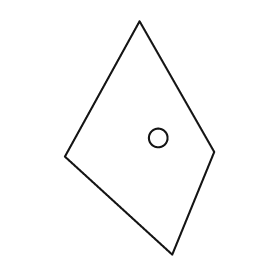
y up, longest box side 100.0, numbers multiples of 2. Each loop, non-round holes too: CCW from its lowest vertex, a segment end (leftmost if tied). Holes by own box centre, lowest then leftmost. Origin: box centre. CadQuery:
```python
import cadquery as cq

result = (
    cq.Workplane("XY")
    .moveTo(14.0, -50.0)
    .lineTo(32.0, -6.0)
    .lineTo(0.0, 50.0)
    .lineTo(-32.0, -8.0)
    .close()
    .moveTo(8.0, 0.0)
    .circle(4.0)
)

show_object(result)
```